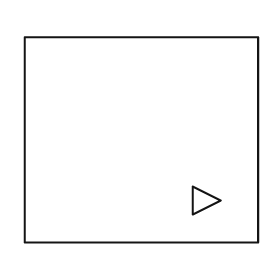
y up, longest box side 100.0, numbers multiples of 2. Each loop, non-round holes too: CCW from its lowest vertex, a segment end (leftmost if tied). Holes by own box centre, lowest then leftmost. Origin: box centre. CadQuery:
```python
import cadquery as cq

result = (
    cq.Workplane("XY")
    .moveTo(-50.0, -44.0)
    .lineTo(50.0, -44.0)
    .lineTo(50.0, 44.0)
    .lineTo(-50.0, 44.0)
    .close()
    .moveTo(22.0, -32.0)
    .lineTo(34.0, -26.0)
    .lineTo(22.0, -20.0)
    .close()
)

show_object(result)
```